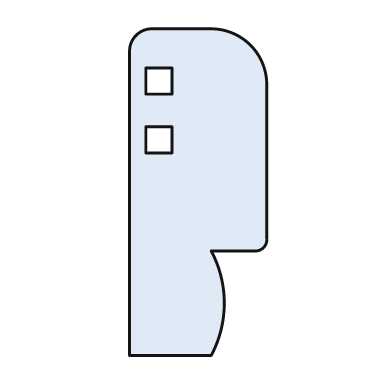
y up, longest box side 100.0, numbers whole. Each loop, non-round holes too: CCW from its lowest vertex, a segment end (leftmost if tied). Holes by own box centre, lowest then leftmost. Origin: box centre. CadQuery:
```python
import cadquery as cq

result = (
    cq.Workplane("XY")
    .moveTo(-21.0, -50.0)
    .lineTo(4.0, -50.0)
    .threePointArc((8.0, -34.0), (4.0, -18.0))
    .lineTo(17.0, -18.0)
    .threePointArc((20.0, -17.0), (21.0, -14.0))
    .lineTo(21.0, 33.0)
    .threePointArc((16.0, 45.0), (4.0, 50.0))
    .lineTo(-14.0, 50.0)
    .threePointArc((-19.0, 48.0), (-21.0, 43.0))
    .close()
    .moveTo(-16.0, 12.0)
    .lineTo(-8.0, 12.0)
    .lineTo(-8.0, 20.0)
    .lineTo(-16.0, 20.0)
    .close()
    .moveTo(-16.0, 30.0)
    .lineTo(-8.0, 30.0)
    .lineTo(-8.0, 38.0)
    .lineTo(-16.0, 38.0)
    .close()
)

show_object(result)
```